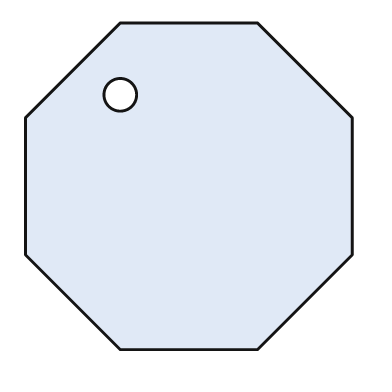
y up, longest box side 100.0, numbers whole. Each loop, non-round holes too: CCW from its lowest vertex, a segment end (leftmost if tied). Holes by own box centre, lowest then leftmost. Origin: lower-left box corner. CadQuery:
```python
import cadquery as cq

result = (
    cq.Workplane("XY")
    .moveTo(29.0, 0.0)
    .lineTo(71.0, 0.0)
    .lineTo(100.0, 29.0)
    .lineTo(100.0, 71.0)
    .lineTo(71.0, 100.0)
    .lineTo(29.0, 100.0)
    .lineTo(0.0, 71.0)
    .lineTo(0.0, 29.0)
    .close()
    .moveTo(29.0, 78.0)
    .circle(5.0)
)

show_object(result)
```